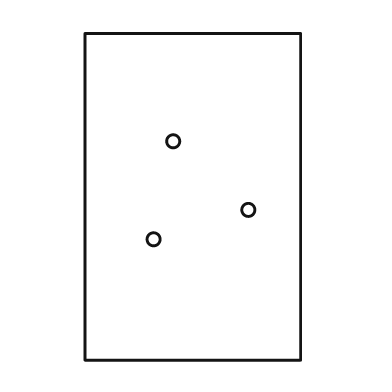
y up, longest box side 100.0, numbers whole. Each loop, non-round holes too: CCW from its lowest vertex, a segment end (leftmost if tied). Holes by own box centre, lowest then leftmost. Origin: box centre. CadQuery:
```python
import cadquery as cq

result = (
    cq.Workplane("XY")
    .moveTo(-33.0, -50.0)
    .lineTo(33.0, -50.0)
    .lineTo(33.0, 50.0)
    .lineTo(-33.0, 50.0)
    .close()
    .moveTo(-12.0, -13.0)
    .circle(2.0)
    .moveTo(17.0, -4.0)
    .circle(2.0)
    .moveTo(-6.0, 17.0)
    .circle(2.0)
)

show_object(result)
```